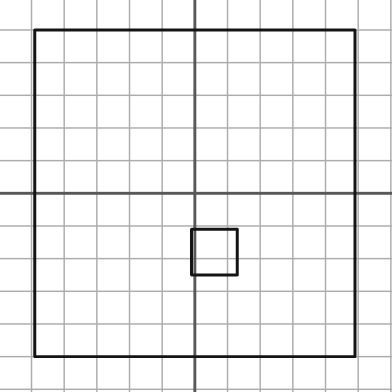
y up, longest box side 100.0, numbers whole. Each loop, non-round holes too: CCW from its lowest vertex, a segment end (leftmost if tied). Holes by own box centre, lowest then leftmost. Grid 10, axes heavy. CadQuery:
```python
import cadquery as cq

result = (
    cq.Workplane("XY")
    .moveTo(-49.0, -50.0)
    .lineTo(49.0, -50.0)
    .lineTo(49.0, 50.0)
    .lineTo(-49.0, 50.0)
    .close()
    .moveTo(-1.0, -25.0)
    .lineTo(13.0, -25.0)
    .lineTo(13.0, -11.0)
    .lineTo(-1.0, -11.0)
    .close()
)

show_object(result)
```